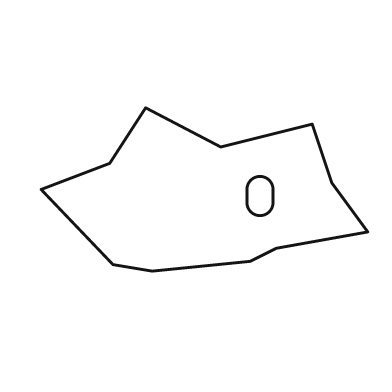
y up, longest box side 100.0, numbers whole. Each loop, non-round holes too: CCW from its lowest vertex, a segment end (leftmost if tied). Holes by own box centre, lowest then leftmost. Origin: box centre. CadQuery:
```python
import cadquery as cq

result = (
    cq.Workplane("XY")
    .moveTo(-16.0, -25.0)
    .lineTo(14.0, -22.0)
    .lineTo(22.0, -18.0)
    .lineTo(50.0, -13.0)
    .lineTo(39.0, 2.0)
    .lineTo(33.0, 20.0)
    .lineTo(5.0, 13.0)
    .lineTo(-18.0, 25.0)
    .lineTo(-29.0, 8.0)
    .lineTo(-50.0, 0.0)
    .lineTo(-28.0, -23.0)
    .close()
    .moveTo(13.0, -4.0)
    .threePointArc((17.0, -8.0), (21.0, -4.0))
    .lineTo(21.0, 0.0)
    .threePointArc((17.0, 4.0), (13.0, 0.0))
    .close()
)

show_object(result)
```